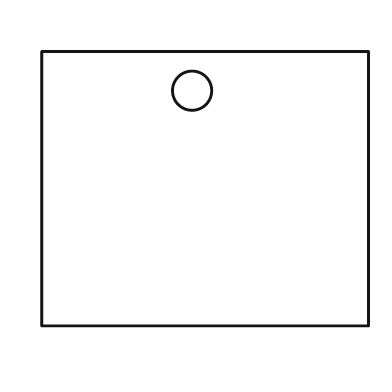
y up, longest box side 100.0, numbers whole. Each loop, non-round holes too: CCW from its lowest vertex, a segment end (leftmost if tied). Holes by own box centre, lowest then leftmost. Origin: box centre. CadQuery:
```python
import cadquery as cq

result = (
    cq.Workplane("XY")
    .moveTo(-50.0, -42.0)
    .lineTo(50.0, -42.0)
    .lineTo(50.0, 42.0)
    .lineTo(-50.0, 42.0)
    .close()
    .moveTo(-4.0, 30.0)
    .circle(6.0)
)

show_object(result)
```